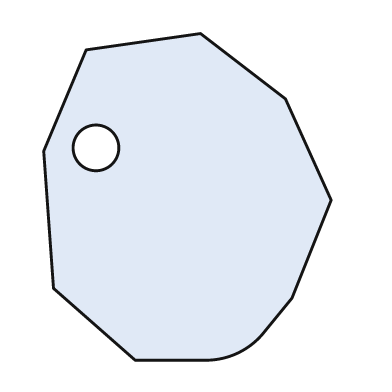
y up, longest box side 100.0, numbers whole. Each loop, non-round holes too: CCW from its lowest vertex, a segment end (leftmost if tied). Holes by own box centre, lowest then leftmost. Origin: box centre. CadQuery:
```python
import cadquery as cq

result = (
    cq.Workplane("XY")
    .moveTo(-16.0, -50.0)
    .lineTo(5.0, -50.0)
    .threePointArc((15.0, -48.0), (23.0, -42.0))
    .lineTo(32.0, -31.0)
    .lineTo(44.0, -1.0)
    .lineTo(30.0, 30.0)
    .lineTo(4.0, 50.0)
    .lineTo(-31.0, 45.0)
    .lineTo(-44.0, 14.0)
    .lineTo(-41.0, -28.0)
    .close()
    .moveTo(-28.0, 15.0)
    .circle(7.0)
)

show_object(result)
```